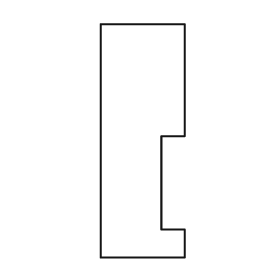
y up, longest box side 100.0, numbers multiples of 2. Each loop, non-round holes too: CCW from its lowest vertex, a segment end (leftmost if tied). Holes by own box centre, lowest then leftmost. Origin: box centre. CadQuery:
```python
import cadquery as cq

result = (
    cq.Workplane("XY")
    .moveTo(-18.0, -50.0)
    .lineTo(18.0, -50.0)
    .lineTo(18.0, -38.0)
    .lineTo(8.0, -38.0)
    .lineTo(8.0, 2.0)
    .lineTo(18.0, 2.0)
    .lineTo(18.0, 50.0)
    .lineTo(-18.0, 50.0)
    .close()
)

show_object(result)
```